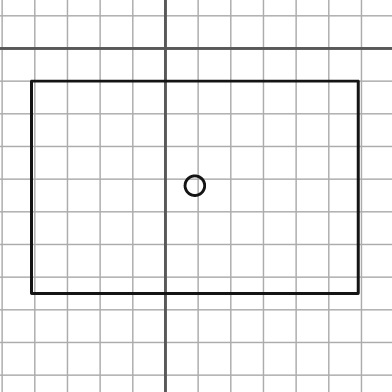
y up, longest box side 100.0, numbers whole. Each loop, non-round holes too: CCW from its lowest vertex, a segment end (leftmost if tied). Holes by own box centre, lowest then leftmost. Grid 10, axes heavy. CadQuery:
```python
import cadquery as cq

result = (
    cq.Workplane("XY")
    .moveTo(-41.0, -75.0)
    .lineTo(59.0, -75.0)
    .lineTo(59.0, -10.0)
    .lineTo(-41.0, -10.0)
    .close()
    .moveTo(9.0, -42.0)
    .circle(3.0)
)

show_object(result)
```